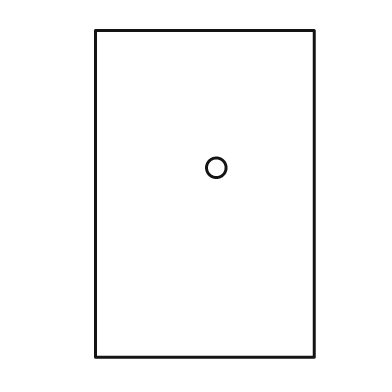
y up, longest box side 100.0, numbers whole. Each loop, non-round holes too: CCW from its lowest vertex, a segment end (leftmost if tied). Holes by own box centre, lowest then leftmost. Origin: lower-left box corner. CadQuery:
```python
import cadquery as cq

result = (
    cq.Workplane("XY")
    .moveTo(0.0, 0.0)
    .lineTo(67.0, 0.0)
    .lineTo(67.0, 100.0)
    .lineTo(0.0, 100.0)
    .close()
    .moveTo(37.0, 58.0)
    .circle(3.0)
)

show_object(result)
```